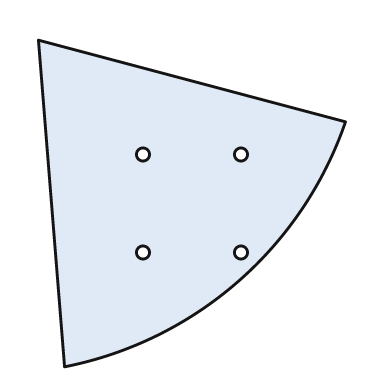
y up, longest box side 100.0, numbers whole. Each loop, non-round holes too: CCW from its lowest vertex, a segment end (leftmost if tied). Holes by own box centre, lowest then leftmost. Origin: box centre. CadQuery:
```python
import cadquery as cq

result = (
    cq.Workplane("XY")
    .moveTo(-39.0, -50.0)
    .threePointArc((14.0, -24.0), (47.0, 25.0))
    .lineTo(-47.0, 50.0)
    .close()
    .moveTo(-15.0, -15.0)
    .circle(2.0)
    .moveTo(15.0, -15.0)
    .circle(2.0)
    .moveTo(-15.0, 15.0)
    .circle(2.0)
    .moveTo(15.0, 15.0)
    .circle(2.0)
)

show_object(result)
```